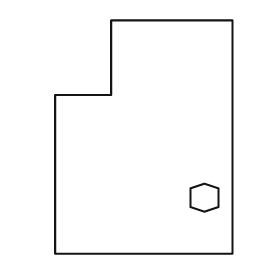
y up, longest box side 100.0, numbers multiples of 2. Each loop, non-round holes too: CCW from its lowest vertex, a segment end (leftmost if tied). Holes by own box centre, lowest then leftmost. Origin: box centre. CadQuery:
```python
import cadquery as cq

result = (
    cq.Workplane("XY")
    .moveTo(-38.0, -50.0)
    .lineTo(38.0, -50.0)
    .lineTo(38.0, 50.0)
    .lineTo(-14.0, 50.0)
    .lineTo(-14.0, 18.0)
    .lineTo(-38.0, 18.0)
    .close()
    .moveTo(26.0, -32.0)
    .lineTo(32.0, -30.0)
    .lineTo(32.0, -22.0)
    .lineTo(26.0, -20.0)
    .lineTo(20.0, -22.0)
    .lineTo(20.0, -30.0)
    .close()
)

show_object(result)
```